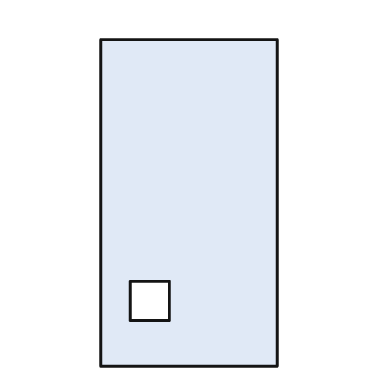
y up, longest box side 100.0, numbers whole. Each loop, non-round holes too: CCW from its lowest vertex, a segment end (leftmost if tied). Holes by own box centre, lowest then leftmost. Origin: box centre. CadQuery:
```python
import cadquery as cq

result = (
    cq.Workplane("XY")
    .moveTo(-27.0, -50.0)
    .lineTo(27.0, -50.0)
    .lineTo(27.0, 50.0)
    .lineTo(-27.0, 50.0)
    .close()
    .moveTo(-18.0, -36.0)
    .lineTo(-6.0, -36.0)
    .lineTo(-6.0, -24.0)
    .lineTo(-18.0, -24.0)
    .close()
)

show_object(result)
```